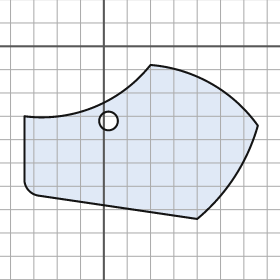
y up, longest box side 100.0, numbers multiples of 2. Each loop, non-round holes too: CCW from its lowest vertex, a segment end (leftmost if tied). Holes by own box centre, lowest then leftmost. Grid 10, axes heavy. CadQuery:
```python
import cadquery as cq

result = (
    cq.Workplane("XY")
    .moveTo(40.0, -74.0)
    .threePointArc((56.0, -56.0), (66.0, -34.0))
    .threePointArc((46.0, -16.0), (20.0, -8.0))
    .threePointArc((-4.0, -26.0), (-34.0, -30.0))
    .lineTo(-34.0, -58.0)
    .threePointArc((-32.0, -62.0), (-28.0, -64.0))
    .close()
    .moveTo(2.0, -32.0)
    .circle(4.0)
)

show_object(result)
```